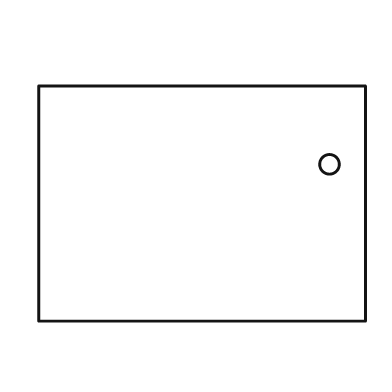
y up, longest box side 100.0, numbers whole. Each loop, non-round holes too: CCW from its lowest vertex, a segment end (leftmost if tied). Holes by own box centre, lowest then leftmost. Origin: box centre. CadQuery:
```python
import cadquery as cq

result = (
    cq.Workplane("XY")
    .moveTo(-50.0, -36.0)
    .lineTo(50.0, -36.0)
    .lineTo(50.0, 36.0)
    .lineTo(-50.0, 36.0)
    .close()
    .moveTo(39.0, 12.0)
    .circle(3.0)
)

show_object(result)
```